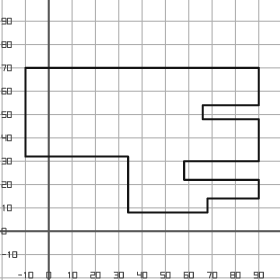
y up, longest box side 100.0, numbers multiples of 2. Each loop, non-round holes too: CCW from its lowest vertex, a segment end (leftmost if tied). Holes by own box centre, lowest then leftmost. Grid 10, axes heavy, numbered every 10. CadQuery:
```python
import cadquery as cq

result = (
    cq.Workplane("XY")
    .moveTo(34.0, 8.0)
    .lineTo(68.0, 8.0)
    .lineTo(68.0, 14.0)
    .lineTo(90.0, 14.0)
    .lineTo(90.0, 22.0)
    .lineTo(58.0, 22.0)
    .lineTo(58.0, 30.0)
    .lineTo(90.0, 30.0)
    .lineTo(90.0, 48.0)
    .lineTo(66.0, 48.0)
    .lineTo(66.0, 54.0)
    .lineTo(90.0, 54.0)
    .lineTo(90.0, 70.0)
    .lineTo(-10.0, 70.0)
    .lineTo(-10.0, 32.0)
    .lineTo(34.0, 32.0)
    .close()
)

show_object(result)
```